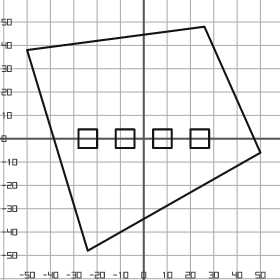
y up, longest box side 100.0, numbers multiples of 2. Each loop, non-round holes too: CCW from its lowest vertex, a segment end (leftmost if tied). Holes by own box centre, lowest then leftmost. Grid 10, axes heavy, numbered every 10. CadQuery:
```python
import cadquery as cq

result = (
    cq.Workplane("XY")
    .moveTo(-24.0, -48.0)
    .lineTo(50.0, -6.0)
    .lineTo(26.0, 48.0)
    .lineTo(-50.0, 38.0)
    .close()
    .moveTo(-28.0, -4.0)
    .lineTo(-20.0, -4.0)
    .lineTo(-20.0, 4.0)
    .lineTo(-28.0, 4.0)
    .close()
    .moveTo(-12.0, -4.0)
    .lineTo(-4.0, -4.0)
    .lineTo(-4.0, 4.0)
    .lineTo(-12.0, 4.0)
    .close()
    .moveTo(4.0, -4.0)
    .lineTo(12.0, -4.0)
    .lineTo(12.0, 4.0)
    .lineTo(4.0, 4.0)
    .close()
    .moveTo(20.0, -4.0)
    .lineTo(28.0, -4.0)
    .lineTo(28.0, 4.0)
    .lineTo(20.0, 4.0)
    .close()
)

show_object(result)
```